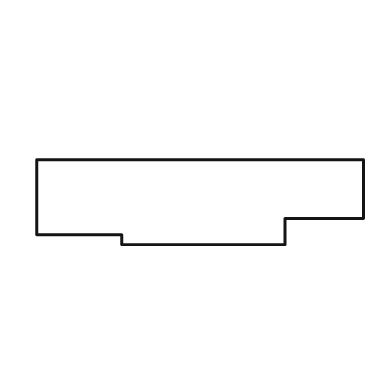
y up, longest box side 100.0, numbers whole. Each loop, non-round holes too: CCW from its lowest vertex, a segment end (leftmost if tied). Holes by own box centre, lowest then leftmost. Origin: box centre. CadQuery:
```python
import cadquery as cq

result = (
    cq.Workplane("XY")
    .moveTo(-24.0, -13.0)
    .lineTo(26.0, -13.0)
    .lineTo(26.0, -5.0)
    .lineTo(50.0, -5.0)
    .lineTo(50.0, 13.0)
    .lineTo(-50.0, 13.0)
    .lineTo(-50.0, -10.0)
    .lineTo(-24.0, -10.0)
    .close()
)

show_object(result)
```